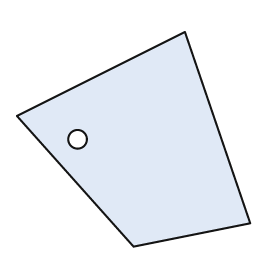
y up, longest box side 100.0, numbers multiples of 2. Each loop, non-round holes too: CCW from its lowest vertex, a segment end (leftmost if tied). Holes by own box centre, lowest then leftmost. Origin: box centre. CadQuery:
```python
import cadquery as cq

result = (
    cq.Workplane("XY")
    .moveTo(0.0, -46.0)
    .lineTo(50.0, -36.0)
    .lineTo(22.0, 46.0)
    .lineTo(-50.0, 10.0)
    .close()
    .moveTo(-24.0, 0.0)
    .circle(4.0)
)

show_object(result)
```